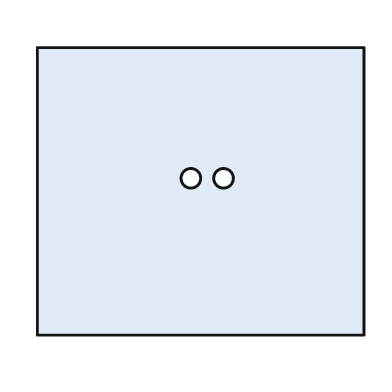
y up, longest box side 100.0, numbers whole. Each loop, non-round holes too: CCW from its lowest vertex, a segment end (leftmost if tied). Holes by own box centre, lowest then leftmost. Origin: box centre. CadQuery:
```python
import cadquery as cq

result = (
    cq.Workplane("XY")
    .moveTo(-50.0, -44.0)
    .lineTo(50.0, -44.0)
    .lineTo(50.0, 44.0)
    .lineTo(-50.0, 44.0)
    .close()
    .moveTo(-3.0, 4.0)
    .circle(3.0)
    .moveTo(7.0, 4.0)
    .circle(3.0)
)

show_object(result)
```